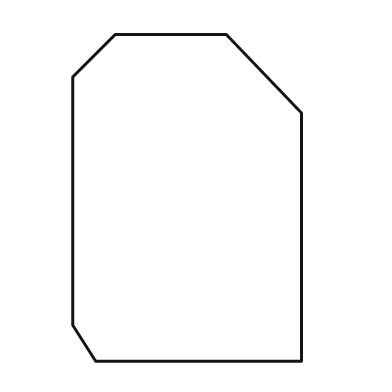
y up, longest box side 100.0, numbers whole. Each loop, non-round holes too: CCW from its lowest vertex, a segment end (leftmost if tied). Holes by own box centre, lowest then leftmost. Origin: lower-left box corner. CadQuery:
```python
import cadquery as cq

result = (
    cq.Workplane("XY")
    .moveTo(7.0, 0.0)
    .lineTo(70.0, 0.0)
    .lineTo(70.0, 76.0)
    .lineTo(47.0, 100.0)
    .lineTo(13.0, 100.0)
    .lineTo(0.0, 87.0)
    .lineTo(0.0, 11.0)
    .close()
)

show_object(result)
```